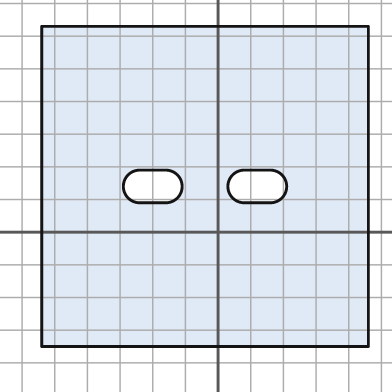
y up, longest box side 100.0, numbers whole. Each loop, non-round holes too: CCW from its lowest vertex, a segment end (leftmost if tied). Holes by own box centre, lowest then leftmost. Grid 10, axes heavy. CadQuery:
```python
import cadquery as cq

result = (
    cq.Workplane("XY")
    .moveTo(-54.0, -35.0)
    .lineTo(46.0, -35.0)
    .lineTo(46.0, 63.0)
    .lineTo(-54.0, 63.0)
    .close()
    .moveTo(-24.0, 9.0)
    .lineTo(-16.0, 9.0)
    .threePointArc((-11.0, 14.0), (-16.0, 19.0))
    .lineTo(-24.0, 19.0)
    .threePointArc((-29.0, 14.0), (-24.0, 9.0))
    .close()
    .moveTo(8.0, 9.0)
    .lineTo(16.0, 9.0)
    .threePointArc((21.0, 14.0), (16.0, 19.0))
    .lineTo(8.0, 19.0)
    .threePointArc((3.0, 14.0), (8.0, 9.0))
    .close()
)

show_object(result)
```